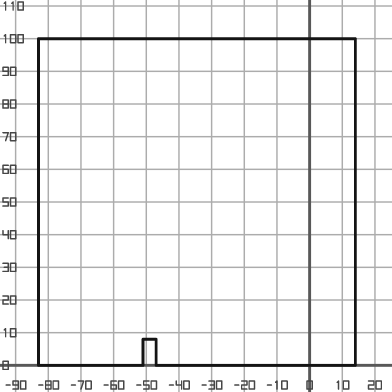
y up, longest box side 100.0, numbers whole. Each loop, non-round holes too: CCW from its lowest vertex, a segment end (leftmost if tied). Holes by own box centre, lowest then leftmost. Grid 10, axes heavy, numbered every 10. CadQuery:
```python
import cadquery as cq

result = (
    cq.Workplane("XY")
    .moveTo(-83.0, 0.0)
    .lineTo(-51.0, 0.0)
    .lineTo(-51.0, 8.0)
    .lineTo(-47.0, 8.0)
    .lineTo(-47.0, 0.0)
    .lineTo(14.0, 0.0)
    .lineTo(14.0, 100.0)
    .lineTo(-83.0, 100.0)
    .close()
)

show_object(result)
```